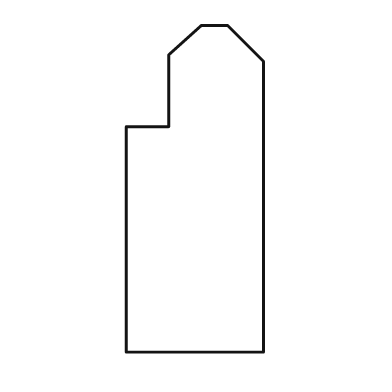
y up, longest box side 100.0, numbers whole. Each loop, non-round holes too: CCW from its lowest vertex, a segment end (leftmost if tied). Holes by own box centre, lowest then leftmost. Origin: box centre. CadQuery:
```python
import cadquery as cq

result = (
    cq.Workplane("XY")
    .moveTo(-21.0, -50.0)
    .lineTo(21.0, -50.0)
    .lineTo(21.0, 39.0)
    .lineTo(10.0, 50.0)
    .lineTo(2.0, 50.0)
    .lineTo(-8.0, 41.0)
    .lineTo(-8.0, 19.0)
    .lineTo(-21.0, 19.0)
    .close()
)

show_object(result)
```